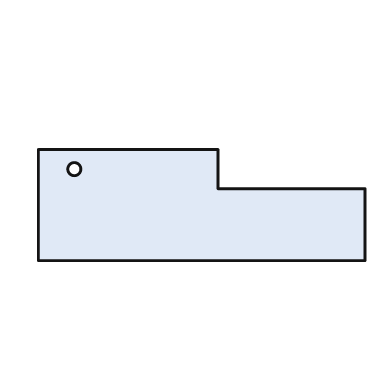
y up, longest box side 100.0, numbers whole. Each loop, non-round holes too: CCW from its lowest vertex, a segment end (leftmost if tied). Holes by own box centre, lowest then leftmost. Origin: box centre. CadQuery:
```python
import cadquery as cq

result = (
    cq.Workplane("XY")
    .moveTo(-50.0, -17.0)
    .lineTo(50.0, -17.0)
    .lineTo(50.0, 5.0)
    .lineTo(5.0, 5.0)
    .lineTo(5.0, 17.0)
    .lineTo(-50.0, 17.0)
    .close()
    .moveTo(-39.0, 11.0)
    .circle(2.0)
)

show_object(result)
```